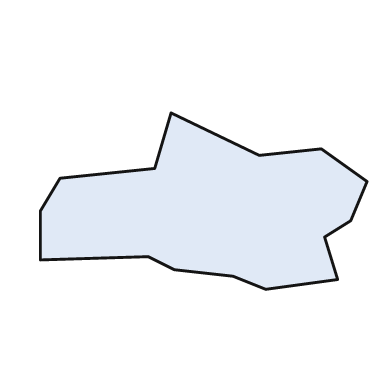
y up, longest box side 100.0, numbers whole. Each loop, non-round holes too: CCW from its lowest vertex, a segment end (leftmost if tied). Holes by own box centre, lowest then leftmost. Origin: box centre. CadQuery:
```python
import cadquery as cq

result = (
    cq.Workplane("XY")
    .moveTo(19.0, -27.0)
    .lineTo(41.0, -24.0)
    .lineTo(37.0, -11.0)
    .lineTo(45.0, -6.0)
    .lineTo(50.0, 6.0)
    .lineTo(36.0, 16.0)
    .lineTo(17.0, 14.0)
    .lineTo(-10.0, 27.0)
    .lineTo(-15.0, 10.0)
    .lineTo(-44.0, 7.0)
    .lineTo(-50.0, -3.0)
    .lineTo(-50.0, -18.0)
    .lineTo(-17.0, -17.0)
    .lineTo(-9.0, -21.0)
    .lineTo(9.0, -23.0)
    .close()
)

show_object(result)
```